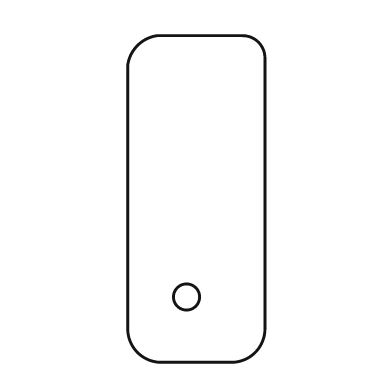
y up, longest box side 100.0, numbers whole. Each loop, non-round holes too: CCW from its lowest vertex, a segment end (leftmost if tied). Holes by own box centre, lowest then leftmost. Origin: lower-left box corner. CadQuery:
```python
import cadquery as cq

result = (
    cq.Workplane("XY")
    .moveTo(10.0, 0.0)
    .lineTo(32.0, 0.0)
    .threePointArc((39.0, 3.0), (42.0, 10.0))
    .lineTo(42.0, 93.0)
    .threePointArc((40.0, 98.0), (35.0, 100.0))
    .lineTo(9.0, 100.0)
    .threePointArc((3.0, 97.0), (0.0, 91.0))
    .lineTo(0.0, 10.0)
    .threePointArc((3.0, 3.0), (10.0, 0.0))
    .close()
    .moveTo(18.0, 20.0)
    .circle(4.0)
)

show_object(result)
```